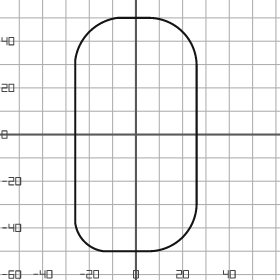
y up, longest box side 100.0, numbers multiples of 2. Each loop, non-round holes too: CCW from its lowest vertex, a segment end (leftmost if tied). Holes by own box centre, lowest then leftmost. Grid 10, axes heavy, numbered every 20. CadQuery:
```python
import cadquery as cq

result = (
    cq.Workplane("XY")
    .moveTo(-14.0, -50.0)
    .lineTo(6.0, -50.0)
    .threePointArc((20.0, -44.0), (26.0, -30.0))
    .lineTo(26.0, 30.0)
    .threePointArc((20.0, 44.0), (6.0, 50.0))
    .lineTo(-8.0, 50.0)
    .threePointArc((-20.0, 44.0), (-26.0, 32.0))
    .lineTo(-26.0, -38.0)
    .threePointArc((-22.0, -46.0), (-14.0, -50.0))
    .close()
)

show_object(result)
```